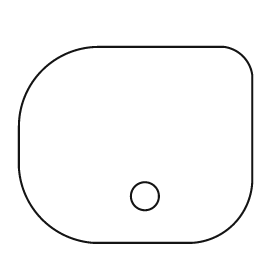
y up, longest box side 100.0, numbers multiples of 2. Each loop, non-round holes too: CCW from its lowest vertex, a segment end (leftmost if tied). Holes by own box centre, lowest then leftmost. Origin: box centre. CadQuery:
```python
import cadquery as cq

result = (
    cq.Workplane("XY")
    .moveTo(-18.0, -42.0)
    .lineTo(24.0, -42.0)
    .threePointArc((42.0, -34.0), (50.0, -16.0))
    .lineTo(50.0, 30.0)
    .threePointArc((46.0, 38.0), (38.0, 42.0))
    .lineTo(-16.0, 42.0)
    .threePointArc((-40.0, 32.0), (-50.0, 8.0))
    .lineTo(-50.0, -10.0)
    .threePointArc((-40.0, -32.0), (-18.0, -42.0))
    .close()
    .moveTo(4.0, -22.0)
    .circle(6.0)
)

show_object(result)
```